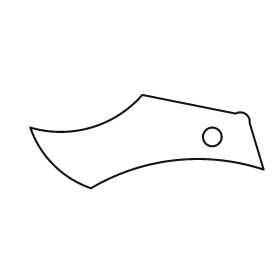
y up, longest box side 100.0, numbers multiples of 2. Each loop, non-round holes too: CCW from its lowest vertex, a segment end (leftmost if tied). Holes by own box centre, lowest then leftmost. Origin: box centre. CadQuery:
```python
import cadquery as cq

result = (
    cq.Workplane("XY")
    .moveTo(-24.0, -20.0)
    .threePointArc((12.0, -8.0), (50.0, -12.0))
    .lineTo(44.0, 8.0)
    .threePointArc((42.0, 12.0), (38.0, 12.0))
    .lineTo(-2.0, 20.0)
    .threePointArc((-24.0, 6.0), (-50.0, 6.0))
    .threePointArc((-40.0, -10.0), (-24.0, -20.0))
    .close()
    .moveTo(28.0, 2.0)
    .circle(4.0)
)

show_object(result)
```